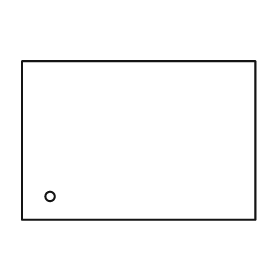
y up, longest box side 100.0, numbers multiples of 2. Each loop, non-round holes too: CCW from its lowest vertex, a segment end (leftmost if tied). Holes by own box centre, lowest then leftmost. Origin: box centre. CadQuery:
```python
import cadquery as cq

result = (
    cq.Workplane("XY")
    .moveTo(-50.0, -34.0)
    .lineTo(50.0, -34.0)
    .lineTo(50.0, 34.0)
    .lineTo(-50.0, 34.0)
    .close()
    .moveTo(-38.0, -24.0)
    .circle(2.0)
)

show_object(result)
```